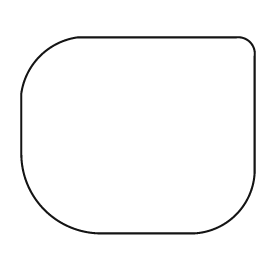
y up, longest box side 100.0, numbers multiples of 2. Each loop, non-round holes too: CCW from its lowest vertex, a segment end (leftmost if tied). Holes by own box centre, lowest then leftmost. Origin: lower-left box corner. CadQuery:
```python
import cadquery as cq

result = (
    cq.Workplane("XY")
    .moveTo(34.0, 0.0)
    .lineTo(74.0, 0.0)
    .threePointArc((92.0, 8.0), (100.0, 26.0))
    .lineTo(100.0, 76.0)
    .threePointArc((98.0, 82.0), (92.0, 84.0))
    .lineTo(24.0, 84.0)
    .threePointArc((8.0, 76.0), (0.0, 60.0))
    .lineTo(0.0, 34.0)
    .threePointArc((10.0, 10.0), (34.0, 0.0))
    .close()
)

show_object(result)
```